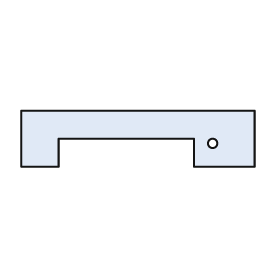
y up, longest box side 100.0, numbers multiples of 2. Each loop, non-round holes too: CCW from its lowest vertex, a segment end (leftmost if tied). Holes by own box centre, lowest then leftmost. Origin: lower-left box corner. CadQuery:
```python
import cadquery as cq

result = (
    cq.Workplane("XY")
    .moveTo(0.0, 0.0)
    .lineTo(16.0, 0.0)
    .lineTo(16.0, 12.0)
    .lineTo(74.0, 12.0)
    .lineTo(74.0, 0.0)
    .lineTo(100.0, 0.0)
    .lineTo(100.0, 24.0)
    .lineTo(0.0, 24.0)
    .close()
    .moveTo(82.0, 10.0)
    .circle(2.0)
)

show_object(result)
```